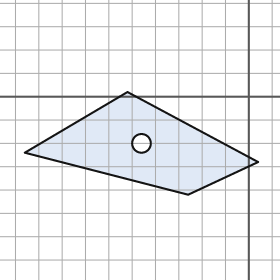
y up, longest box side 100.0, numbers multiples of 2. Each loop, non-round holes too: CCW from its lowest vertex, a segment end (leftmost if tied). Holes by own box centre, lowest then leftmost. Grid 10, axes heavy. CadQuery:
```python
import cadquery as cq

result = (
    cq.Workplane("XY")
    .moveTo(-26.0, -42.0)
    .lineTo(4.0, -28.0)
    .lineTo(-52.0, 2.0)
    .lineTo(-96.0, -24.0)
    .close()
    .moveTo(-46.0, -20.0)
    .circle(4.0)
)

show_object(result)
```